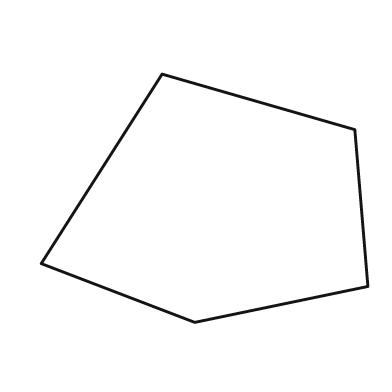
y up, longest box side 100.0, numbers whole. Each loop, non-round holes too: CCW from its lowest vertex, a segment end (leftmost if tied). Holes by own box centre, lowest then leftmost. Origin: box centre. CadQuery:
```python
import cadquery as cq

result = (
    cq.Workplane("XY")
    .moveTo(-3.0, -38.0)
    .lineTo(50.0, -27.0)
    .lineTo(46.0, 21.0)
    .lineTo(-13.0, 38.0)
    .lineTo(-50.0, -20.0)
    .close()
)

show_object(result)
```